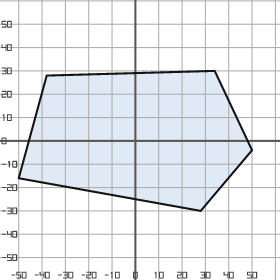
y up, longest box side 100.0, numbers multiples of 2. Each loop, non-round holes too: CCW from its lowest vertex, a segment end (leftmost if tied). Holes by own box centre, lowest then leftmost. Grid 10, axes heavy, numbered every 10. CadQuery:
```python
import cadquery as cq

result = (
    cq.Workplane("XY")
    .moveTo(28.0, -30.0)
    .lineTo(50.0, -4.0)
    .lineTo(34.0, 30.0)
    .lineTo(-38.0, 28.0)
    .lineTo(-50.0, -16.0)
    .close()
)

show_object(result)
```